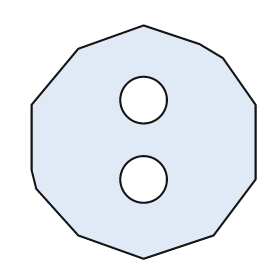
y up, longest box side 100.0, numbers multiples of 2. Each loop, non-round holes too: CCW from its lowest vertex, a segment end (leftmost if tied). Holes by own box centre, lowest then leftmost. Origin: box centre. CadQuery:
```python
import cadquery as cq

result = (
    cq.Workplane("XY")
    .moveTo(0.0, -50.0)
    .lineTo(30.0, -40.0)
    .lineTo(48.0, -16.0)
    .lineTo(48.0, 16.0)
    .lineTo(34.0, 36.0)
    .lineTo(24.0, 42.0)
    .lineTo(0.0, 50.0)
    .lineTo(-28.0, 40.0)
    .lineTo(-48.0, 16.0)
    .lineTo(-48.0, -12.0)
    .lineTo(-46.0, -20.0)
    .lineTo(-28.0, -40.0)
    .close()
    .moveTo(0.0, -16.0)
    .circle(10.0)
    .moveTo(0.0, 18.0)
    .circle(10.0)
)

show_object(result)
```